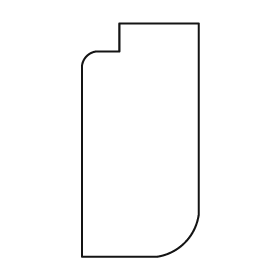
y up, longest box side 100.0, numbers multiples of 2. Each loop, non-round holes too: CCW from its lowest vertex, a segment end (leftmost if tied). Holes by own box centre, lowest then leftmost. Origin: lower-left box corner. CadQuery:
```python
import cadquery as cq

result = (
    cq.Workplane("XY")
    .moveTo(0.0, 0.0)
    .lineTo(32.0, 0.0)
    .threePointArc((44.0, 6.0), (50.0, 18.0))
    .lineTo(50.0, 100.0)
    .lineTo(16.0, 100.0)
    .lineTo(16.0, 88.0)
    .lineTo(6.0, 88.0)
    .threePointArc((2.0, 86.0), (0.0, 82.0))
    .close()
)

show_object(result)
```